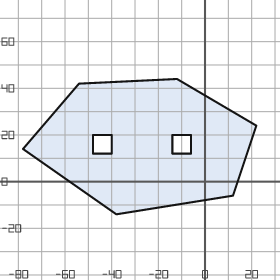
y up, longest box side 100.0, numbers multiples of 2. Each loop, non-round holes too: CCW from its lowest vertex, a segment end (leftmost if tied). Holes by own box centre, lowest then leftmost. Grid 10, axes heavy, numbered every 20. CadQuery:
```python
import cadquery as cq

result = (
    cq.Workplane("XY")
    .moveTo(-38.0, -14.0)
    .lineTo(12.0, -6.0)
    .lineTo(22.0, 24.0)
    .lineTo(-12.0, 44.0)
    .lineTo(-54.0, 42.0)
    .lineTo(-78.0, 14.0)
    .close()
    .moveTo(-48.0, 12.0)
    .lineTo(-40.0, 12.0)
    .lineTo(-40.0, 20.0)
    .lineTo(-48.0, 20.0)
    .close()
    .moveTo(-14.0, 12.0)
    .lineTo(-6.0, 12.0)
    .lineTo(-6.0, 20.0)
    .lineTo(-14.0, 20.0)
    .close()
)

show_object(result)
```